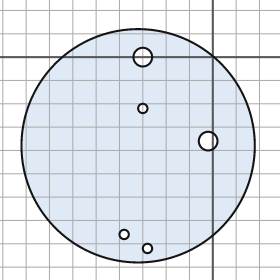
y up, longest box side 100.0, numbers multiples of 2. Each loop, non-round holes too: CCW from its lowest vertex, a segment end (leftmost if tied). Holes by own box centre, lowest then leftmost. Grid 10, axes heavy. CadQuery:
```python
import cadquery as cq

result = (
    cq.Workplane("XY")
    .moveTo(-32.0, -38.0)
    .circle(50.0)
    .moveTo(-28.0, -82.0)
    .circle(2.0)
    .moveTo(-38.0, -76.0)
    .circle(2.0)
    .moveTo(-2.0, -36.0)
    .circle(4.0)
    .moveTo(-30.0, -22.0)
    .circle(2.0)
    .moveTo(-30.0, 0.0)
    .circle(4.0)
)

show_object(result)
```